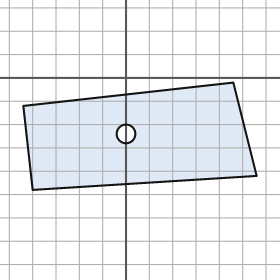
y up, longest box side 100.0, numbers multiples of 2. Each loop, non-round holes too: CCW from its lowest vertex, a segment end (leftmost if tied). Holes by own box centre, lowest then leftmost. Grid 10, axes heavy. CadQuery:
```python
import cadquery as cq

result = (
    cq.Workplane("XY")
    .moveTo(-40.0, -48.0)
    .lineTo(56.0, -42.0)
    .lineTo(46.0, -2.0)
    .lineTo(-44.0, -12.0)
    .close()
    .moveTo(0.0, -24.0)
    .circle(4.0)
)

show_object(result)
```